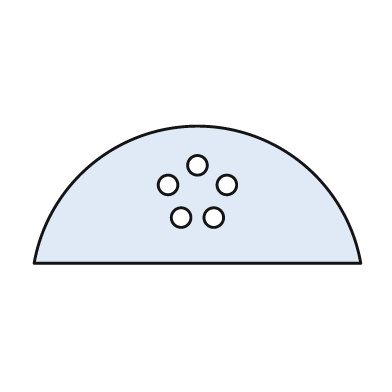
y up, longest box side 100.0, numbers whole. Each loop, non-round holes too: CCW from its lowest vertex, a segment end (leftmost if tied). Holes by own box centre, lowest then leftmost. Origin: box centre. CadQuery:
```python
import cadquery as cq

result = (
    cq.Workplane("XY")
    .moveTo(-50.0, -21.0)
    .lineTo(50.0, -21.0)
    .threePointArc((0.0, 21.0), (-50.0, -21.0))
    .close()
    .moveTo(-5.0, -7.0)
    .circle(3.0)
    .moveTo(5.0, -7.0)
    .circle(3.0)
    .moveTo(-9.0, 3.0)
    .circle(3.0)
    .moveTo(9.0, 3.0)
    .circle(3.0)
    .moveTo(0.0, 9.0)
    .circle(3.0)
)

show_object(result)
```